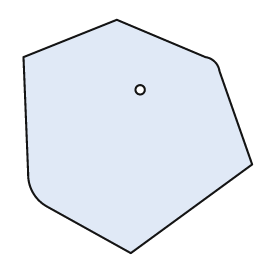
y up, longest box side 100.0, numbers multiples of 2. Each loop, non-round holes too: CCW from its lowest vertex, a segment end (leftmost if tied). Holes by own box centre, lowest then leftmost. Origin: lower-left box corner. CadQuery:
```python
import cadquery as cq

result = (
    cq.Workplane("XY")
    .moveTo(46.0, 0.0)
    .lineTo(98.0, 38.0)
    .lineTo(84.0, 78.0)
    .threePointArc((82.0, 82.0), (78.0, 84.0))
    .lineTo(40.0, 100.0)
    .lineTo(0.0, 84.0)
    .lineTo(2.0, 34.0)
    .threePointArc((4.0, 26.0), (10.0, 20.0))
    .close()
    .moveTo(50.0, 70.0)
    .circle(2.0)
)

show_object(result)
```